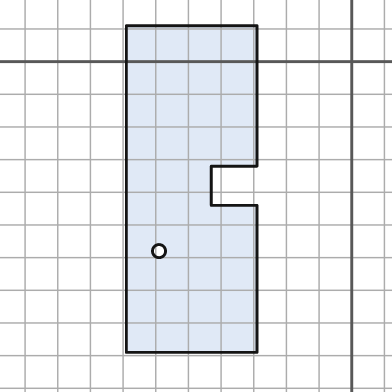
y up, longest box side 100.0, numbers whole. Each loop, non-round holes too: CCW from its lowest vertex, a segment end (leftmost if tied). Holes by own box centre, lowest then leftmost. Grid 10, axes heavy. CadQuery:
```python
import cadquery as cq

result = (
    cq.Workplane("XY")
    .moveTo(-69.0, -89.0)
    .lineTo(-29.0, -89.0)
    .lineTo(-29.0, -44.0)
    .lineTo(-43.0, -44.0)
    .lineTo(-43.0, -32.0)
    .lineTo(-29.0, -32.0)
    .lineTo(-29.0, 11.0)
    .lineTo(-69.0, 11.0)
    .close()
    .moveTo(-59.0, -58.0)
    .circle(2.0)
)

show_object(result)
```